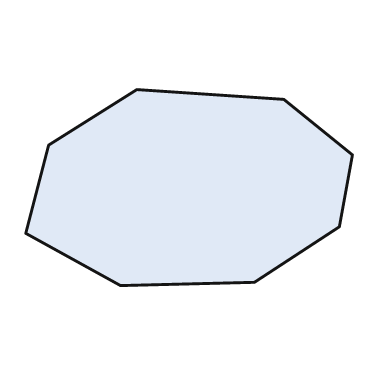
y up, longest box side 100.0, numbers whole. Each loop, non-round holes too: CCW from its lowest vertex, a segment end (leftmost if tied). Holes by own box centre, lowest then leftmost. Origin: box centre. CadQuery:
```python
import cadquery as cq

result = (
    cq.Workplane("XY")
    .moveTo(-21.0, -30.0)
    .lineTo(20.0, -29.0)
    .lineTo(46.0, -12.0)
    .lineTo(50.0, 10.0)
    .lineTo(29.0, 27.0)
    .lineTo(-16.0, 30.0)
    .lineTo(-43.0, 13.0)
    .lineTo(-50.0, -14.0)
    .close()
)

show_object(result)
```